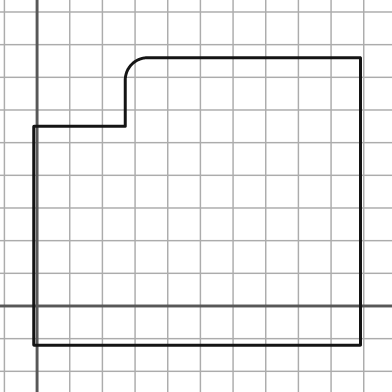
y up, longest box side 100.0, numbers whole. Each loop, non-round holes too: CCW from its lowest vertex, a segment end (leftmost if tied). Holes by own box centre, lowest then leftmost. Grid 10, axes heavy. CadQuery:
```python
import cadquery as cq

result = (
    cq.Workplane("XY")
    .moveTo(-1.0, -12.0)
    .lineTo(99.0, -12.0)
    .lineTo(99.0, 76.0)
    .lineTo(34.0, 76.0)
    .threePointArc((29.0, 74.0), (27.0, 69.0))
    .lineTo(27.0, 55.0)
    .lineTo(-1.0, 55.0)
    .close()
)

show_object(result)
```